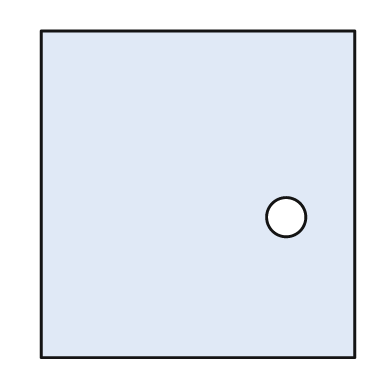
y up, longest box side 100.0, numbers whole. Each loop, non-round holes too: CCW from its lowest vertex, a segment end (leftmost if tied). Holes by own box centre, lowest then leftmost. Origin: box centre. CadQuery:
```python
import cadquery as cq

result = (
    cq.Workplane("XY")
    .moveTo(-48.0, -50.0)
    .lineTo(48.0, -50.0)
    .lineTo(48.0, 50.0)
    .lineTo(-48.0, 50.0)
    .close()
    .moveTo(27.0, -7.0)
    .circle(6.0)
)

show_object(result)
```